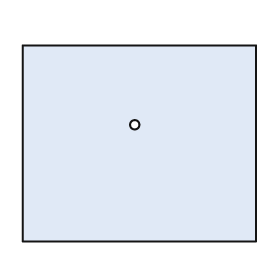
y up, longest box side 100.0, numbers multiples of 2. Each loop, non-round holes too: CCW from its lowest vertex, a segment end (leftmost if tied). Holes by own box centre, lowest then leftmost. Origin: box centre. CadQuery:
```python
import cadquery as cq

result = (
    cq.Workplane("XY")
    .moveTo(-50.0, -42.0)
    .lineTo(50.0, -42.0)
    .lineTo(50.0, 42.0)
    .lineTo(-50.0, 42.0)
    .close()
    .moveTo(-2.0, 8.0)
    .circle(2.0)
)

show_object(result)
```